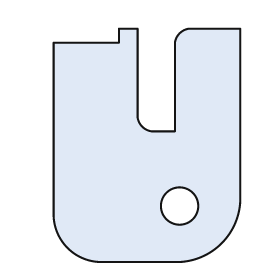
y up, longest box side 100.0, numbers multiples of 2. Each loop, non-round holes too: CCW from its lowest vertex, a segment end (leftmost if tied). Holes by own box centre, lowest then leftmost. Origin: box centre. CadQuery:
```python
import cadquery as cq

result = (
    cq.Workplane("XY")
    .moveTo(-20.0, -50.0)
    .lineTo(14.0, -50.0)
    .threePointArc((32.0, -42.0), (40.0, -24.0))
    .lineTo(40.0, 50.0)
    .lineTo(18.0, 50.0)
    .threePointArc((14.0, 48.0), (12.0, 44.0))
    .lineTo(12.0, 6.0)
    .lineTo(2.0, 6.0)
    .threePointArc((-2.0, 8.0), (-4.0, 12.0))
    .lineTo(-4.0, 50.0)
    .lineTo(-12.0, 50.0)
    .lineTo(-12.0, 44.0)
    .lineTo(-40.0, 44.0)
    .lineTo(-40.0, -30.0)
    .threePointArc((-34.0, -44.0), (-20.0, -50.0))
    .close()
    .moveTo(14.0, -26.0)
    .circle(8.0)
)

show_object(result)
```